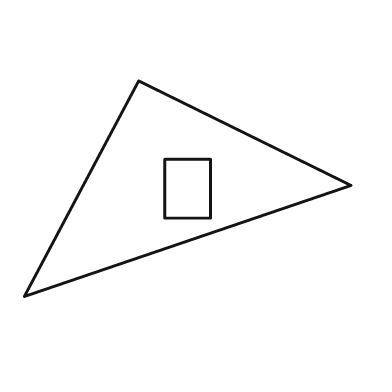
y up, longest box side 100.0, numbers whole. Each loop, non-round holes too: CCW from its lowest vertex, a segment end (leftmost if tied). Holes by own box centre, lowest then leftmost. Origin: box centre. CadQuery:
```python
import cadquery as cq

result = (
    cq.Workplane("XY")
    .moveTo(-50.0, -33.0)
    .lineTo(50.0, 1.0)
    .lineTo(-15.0, 33.0)
    .close()
    .moveTo(-7.0, -9.0)
    .lineTo(7.0, -9.0)
    .lineTo(7.0, 9.0)
    .lineTo(-7.0, 9.0)
    .close()
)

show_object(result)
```